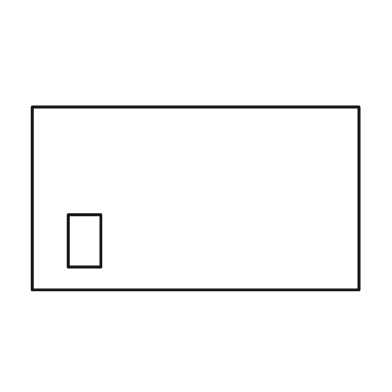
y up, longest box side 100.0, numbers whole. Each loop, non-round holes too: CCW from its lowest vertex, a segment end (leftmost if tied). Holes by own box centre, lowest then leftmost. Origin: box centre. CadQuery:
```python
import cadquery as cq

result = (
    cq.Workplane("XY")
    .moveTo(-50.0, -28.0)
    .lineTo(50.0, -28.0)
    .lineTo(50.0, 28.0)
    .lineTo(-50.0, 28.0)
    .close()
    .moveTo(-39.0, -21.0)
    .lineTo(-29.0, -21.0)
    .lineTo(-29.0, -5.0)
    .lineTo(-39.0, -5.0)
    .close()
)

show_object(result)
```